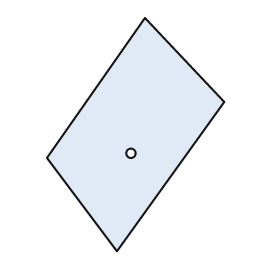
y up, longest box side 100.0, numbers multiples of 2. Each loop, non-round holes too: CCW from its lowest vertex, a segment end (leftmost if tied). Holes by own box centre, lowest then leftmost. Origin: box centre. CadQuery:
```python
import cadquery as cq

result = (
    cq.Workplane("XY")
    .moveTo(-8.0, -50.0)
    .lineTo(38.0, 14.0)
    .lineTo(4.0, 50.0)
    .lineTo(-38.0, -10.0)
    .close()
    .moveTo(-2.0, -8.0)
    .circle(2.0)
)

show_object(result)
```